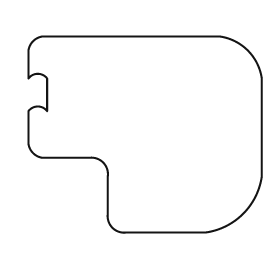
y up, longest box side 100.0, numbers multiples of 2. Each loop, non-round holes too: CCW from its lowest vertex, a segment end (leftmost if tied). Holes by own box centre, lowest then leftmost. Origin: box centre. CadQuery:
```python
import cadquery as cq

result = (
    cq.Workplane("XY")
    .moveTo(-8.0, -42.0)
    .lineTo(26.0, -42.0)
    .threePointArc((42.0, -34.0), (50.0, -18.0))
    .lineTo(50.0, 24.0)
    .threePointArc((44.0, 36.0), (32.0, 42.0))
    .lineTo(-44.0, 42.0)
    .threePointArc((-48.0, 40.0), (-50.0, 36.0))
    .lineTo(-50.0, 24.0)
    .threePointArc((-46.0, 26.0), (-42.0, 24.0))
    .lineTo(-42.0, 10.0)
    .threePointArc((-46.0, 12.0), (-50.0, 10.0))
    .lineTo(-50.0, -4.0)
    .threePointArc((-48.0, -8.0), (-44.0, -10.0))
    .lineTo(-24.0, -10.0)
    .threePointArc((-18.0, -12.0), (-16.0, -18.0))
    .lineTo(-16.0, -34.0)
    .threePointArc((-14.0, -40.0), (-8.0, -42.0))
    .close()
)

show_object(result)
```